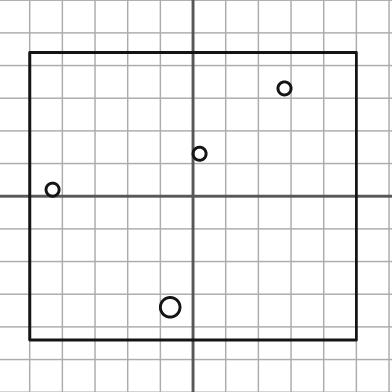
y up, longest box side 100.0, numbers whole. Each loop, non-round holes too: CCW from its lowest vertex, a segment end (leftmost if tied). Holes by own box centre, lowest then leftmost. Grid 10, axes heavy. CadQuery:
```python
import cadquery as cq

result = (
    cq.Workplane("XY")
    .moveTo(-50.0, -44.0)
    .lineTo(50.0, -44.0)
    .lineTo(50.0, 44.0)
    .lineTo(-50.0, 44.0)
    .close()
    .moveTo(-7.0, -34.0)
    .circle(3.0)
    .moveTo(-43.0, 2.0)
    .circle(2.0)
    .moveTo(2.0, 13.0)
    .circle(2.0)
    .moveTo(28.0, 33.0)
    .circle(2.0)
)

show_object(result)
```